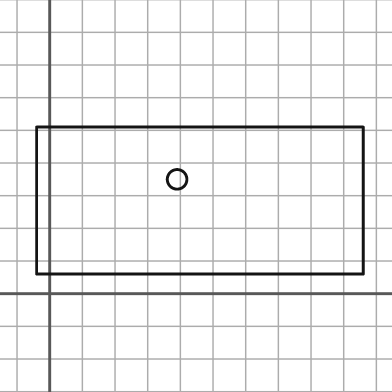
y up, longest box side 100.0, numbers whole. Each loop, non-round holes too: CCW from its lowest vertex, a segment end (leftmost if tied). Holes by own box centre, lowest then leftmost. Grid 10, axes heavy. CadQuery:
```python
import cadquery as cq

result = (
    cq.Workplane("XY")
    .moveTo(-4.0, 6.0)
    .lineTo(96.0, 6.0)
    .lineTo(96.0, 51.0)
    .lineTo(-4.0, 51.0)
    .close()
    .moveTo(39.0, 35.0)
    .circle(3.0)
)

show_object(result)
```